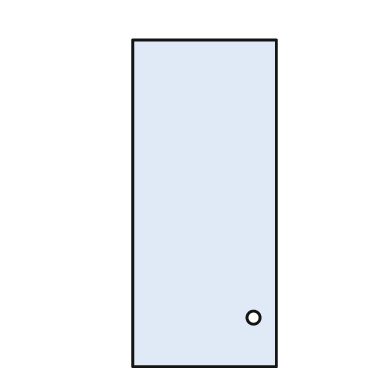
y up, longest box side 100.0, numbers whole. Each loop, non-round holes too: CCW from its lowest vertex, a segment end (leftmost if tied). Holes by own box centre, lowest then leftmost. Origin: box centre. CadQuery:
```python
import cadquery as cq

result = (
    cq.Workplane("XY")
    .moveTo(-22.0, -50.0)
    .lineTo(22.0, -50.0)
    .lineTo(22.0, 50.0)
    .lineTo(-22.0, 50.0)
    .close()
    .moveTo(15.0, -35.0)
    .circle(2.0)
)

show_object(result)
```